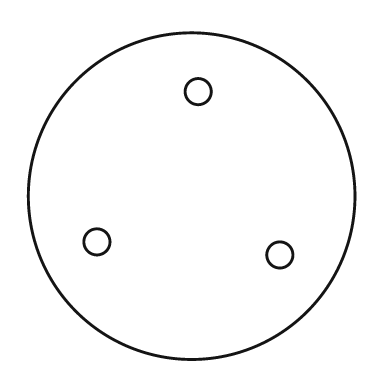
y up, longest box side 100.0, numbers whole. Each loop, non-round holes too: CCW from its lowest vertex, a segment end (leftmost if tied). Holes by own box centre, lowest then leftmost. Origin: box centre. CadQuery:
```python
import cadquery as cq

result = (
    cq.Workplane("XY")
    .moveTo(0.0, 0.0)
    .circle(50.0)
    .moveTo(27.0, -18.0)
    .circle(4.0)
    .moveTo(-29.0, -14.0)
    .circle(4.0)
    .moveTo(2.0, 32.0)
    .circle(4.0)
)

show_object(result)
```